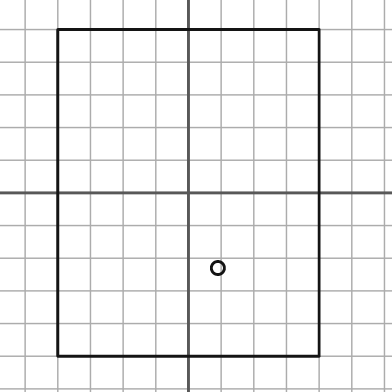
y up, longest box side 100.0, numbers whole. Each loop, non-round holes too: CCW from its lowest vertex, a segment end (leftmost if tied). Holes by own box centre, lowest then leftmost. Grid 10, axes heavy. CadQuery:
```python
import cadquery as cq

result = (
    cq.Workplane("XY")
    .moveTo(-40.0, -50.0)
    .lineTo(40.0, -50.0)
    .lineTo(40.0, 50.0)
    .lineTo(-40.0, 50.0)
    .close()
    .moveTo(9.0, -23.0)
    .circle(2.0)
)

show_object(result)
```